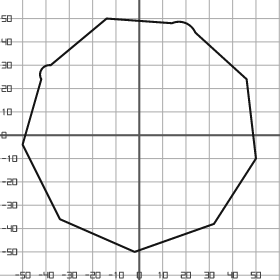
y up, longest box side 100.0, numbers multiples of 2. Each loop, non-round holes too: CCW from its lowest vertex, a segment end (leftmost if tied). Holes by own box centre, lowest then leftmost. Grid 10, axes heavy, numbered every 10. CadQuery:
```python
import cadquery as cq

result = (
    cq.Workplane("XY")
    .moveTo(-2.0, -50.0)
    .lineTo(32.0, -38.0)
    .lineTo(50.0, -10.0)
    .lineTo(46.0, 24.0)
    .lineTo(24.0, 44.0)
    .threePointArc((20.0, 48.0), (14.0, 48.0))
    .lineTo(-14.0, 50.0)
    .lineTo(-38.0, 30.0)
    .threePointArc((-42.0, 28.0), (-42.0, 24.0))
    .lineTo(-50.0, -4.0)
    .lineTo(-34.0, -36.0)
    .close()
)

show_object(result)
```